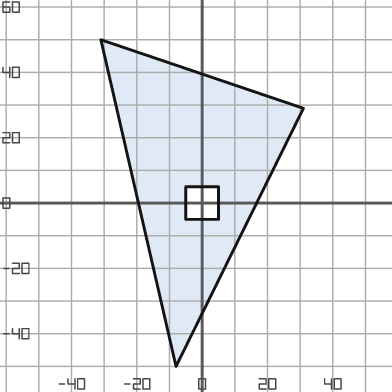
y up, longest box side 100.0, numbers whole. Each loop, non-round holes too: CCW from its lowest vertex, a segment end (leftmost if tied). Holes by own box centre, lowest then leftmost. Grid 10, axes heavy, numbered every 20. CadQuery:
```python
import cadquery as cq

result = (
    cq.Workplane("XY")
    .moveTo(-8.0, -50.0)
    .lineTo(31.0, 29.0)
    .lineTo(-31.0, 50.0)
    .close()
    .moveTo(-5.0, -5.0)
    .lineTo(5.0, -5.0)
    .lineTo(5.0, 5.0)
    .lineTo(-5.0, 5.0)
    .close()
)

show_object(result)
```